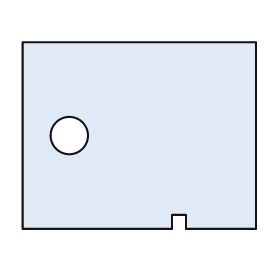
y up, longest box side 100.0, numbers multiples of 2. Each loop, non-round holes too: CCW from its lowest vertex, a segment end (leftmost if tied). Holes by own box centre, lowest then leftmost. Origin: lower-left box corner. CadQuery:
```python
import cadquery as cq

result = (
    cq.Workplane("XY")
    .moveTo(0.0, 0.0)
    .lineTo(64.0, 0.0)
    .lineTo(64.0, 6.0)
    .lineTo(70.0, 6.0)
    .lineTo(70.0, 0.0)
    .lineTo(100.0, 0.0)
    .lineTo(100.0, 80.0)
    .lineTo(0.0, 80.0)
    .close()
    .moveTo(20.0, 40.0)
    .circle(8.0)
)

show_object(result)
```